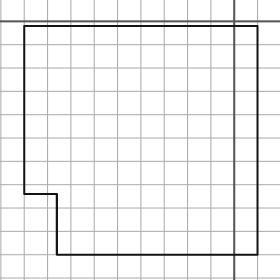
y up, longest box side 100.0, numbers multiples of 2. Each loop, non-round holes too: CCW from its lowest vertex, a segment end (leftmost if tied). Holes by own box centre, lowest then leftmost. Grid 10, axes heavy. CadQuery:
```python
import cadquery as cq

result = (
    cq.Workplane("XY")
    .moveTo(-76.0, -100.0)
    .lineTo(10.0, -100.0)
    .lineTo(10.0, -2.0)
    .lineTo(-90.0, -2.0)
    .lineTo(-90.0, -74.0)
    .lineTo(-76.0, -74.0)
    .close()
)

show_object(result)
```